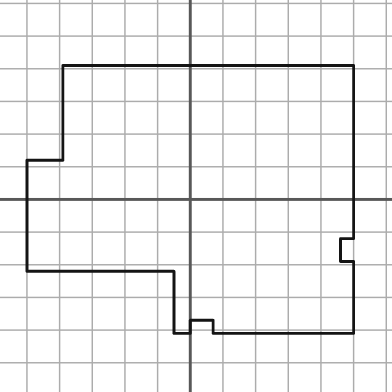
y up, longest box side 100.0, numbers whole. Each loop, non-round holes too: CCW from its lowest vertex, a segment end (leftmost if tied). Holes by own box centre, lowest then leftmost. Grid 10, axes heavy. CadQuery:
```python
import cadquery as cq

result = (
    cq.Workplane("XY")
    .moveTo(-5.0, -41.0)
    .lineTo(0.0, -41.0)
    .lineTo(0.0, -37.0)
    .lineTo(7.0, -37.0)
    .lineTo(7.0, -41.0)
    .lineTo(50.0, -41.0)
    .lineTo(50.0, -19.0)
    .lineTo(46.0, -19.0)
    .lineTo(46.0, -12.0)
    .lineTo(50.0, -12.0)
    .lineTo(50.0, 41.0)
    .lineTo(-39.0, 41.0)
    .lineTo(-39.0, 12.0)
    .lineTo(-50.0, 12.0)
    .lineTo(-50.0, -22.0)
    .lineTo(-5.0, -22.0)
    .close()
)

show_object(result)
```